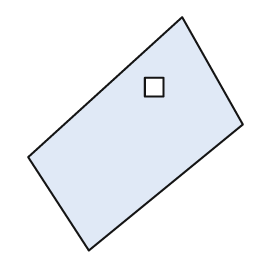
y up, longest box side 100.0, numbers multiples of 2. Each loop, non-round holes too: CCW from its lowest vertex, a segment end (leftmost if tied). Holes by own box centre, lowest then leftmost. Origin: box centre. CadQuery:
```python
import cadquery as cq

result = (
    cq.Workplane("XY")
    .moveTo(-20.0, -50.0)
    .lineTo(46.0, 4.0)
    .lineTo(20.0, 50.0)
    .lineTo(-46.0, -10.0)
    .close()
    .moveTo(4.0, 16.0)
    .lineTo(12.0, 16.0)
    .lineTo(12.0, 24.0)
    .lineTo(4.0, 24.0)
    .close()
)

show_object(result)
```